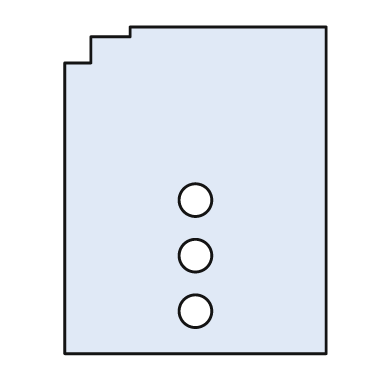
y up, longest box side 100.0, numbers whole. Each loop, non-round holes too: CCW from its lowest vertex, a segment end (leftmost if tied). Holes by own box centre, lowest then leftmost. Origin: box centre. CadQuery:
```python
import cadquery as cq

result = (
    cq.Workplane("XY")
    .moveTo(-40.0, -50.0)
    .lineTo(40.0, -50.0)
    .lineTo(40.0, 50.0)
    .lineTo(-20.0, 50.0)
    .lineTo(-20.0, 47.0)
    .lineTo(-32.0, 47.0)
    .lineTo(-32.0, 39.0)
    .lineTo(-40.0, 39.0)
    .close()
    .moveTo(0.0, -37.0)
    .circle(5.0)
    .moveTo(0.0, -20.0)
    .circle(5.0)
    .moveTo(0.0, -3.0)
    .circle(5.0)
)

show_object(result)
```